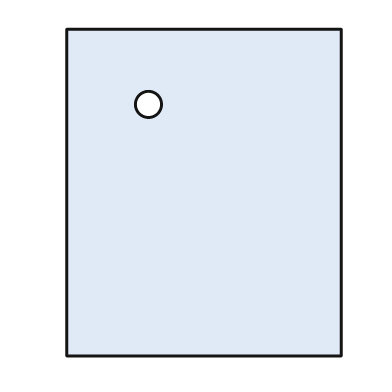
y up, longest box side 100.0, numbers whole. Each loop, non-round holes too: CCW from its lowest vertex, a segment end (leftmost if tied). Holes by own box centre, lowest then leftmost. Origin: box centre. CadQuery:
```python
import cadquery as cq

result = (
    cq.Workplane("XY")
    .moveTo(-42.0, -50.0)
    .lineTo(42.0, -50.0)
    .lineTo(42.0, 50.0)
    .lineTo(-42.0, 50.0)
    .close()
    .moveTo(-17.0, 27.0)
    .circle(4.0)
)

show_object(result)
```